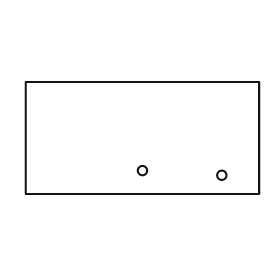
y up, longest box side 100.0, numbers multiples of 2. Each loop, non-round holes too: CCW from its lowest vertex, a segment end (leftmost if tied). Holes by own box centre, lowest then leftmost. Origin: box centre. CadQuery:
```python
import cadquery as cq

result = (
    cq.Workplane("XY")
    .moveTo(-50.0, -24.0)
    .lineTo(50.0, -24.0)
    .lineTo(50.0, 24.0)
    .lineTo(-50.0, 24.0)
    .close()
    .moveTo(34.0, -16.0)
    .circle(2.0)
    .moveTo(0.0, -14.0)
    .circle(2.0)
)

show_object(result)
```